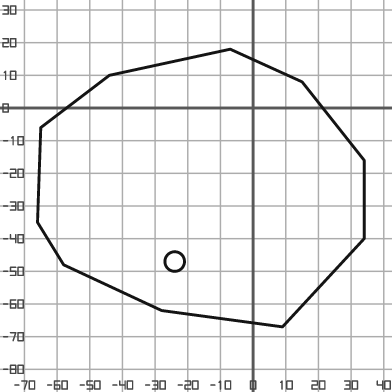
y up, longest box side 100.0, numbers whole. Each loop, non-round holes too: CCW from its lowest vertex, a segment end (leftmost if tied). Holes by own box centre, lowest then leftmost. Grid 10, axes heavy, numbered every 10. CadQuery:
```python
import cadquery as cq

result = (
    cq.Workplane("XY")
    .moveTo(9.0, -67.0)
    .lineTo(34.0, -40.0)
    .lineTo(34.0, -16.0)
    .lineTo(15.0, 8.0)
    .lineTo(-7.0, 18.0)
    .lineTo(-44.0, 10.0)
    .lineTo(-65.0, -6.0)
    .lineTo(-66.0, -35.0)
    .lineTo(-58.0, -48.0)
    .lineTo(-28.0, -62.0)
    .close()
    .moveTo(-24.0, -47.0)
    .circle(3.0)
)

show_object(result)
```